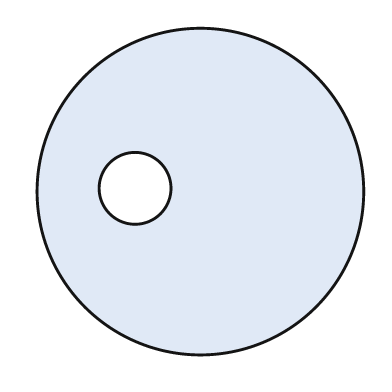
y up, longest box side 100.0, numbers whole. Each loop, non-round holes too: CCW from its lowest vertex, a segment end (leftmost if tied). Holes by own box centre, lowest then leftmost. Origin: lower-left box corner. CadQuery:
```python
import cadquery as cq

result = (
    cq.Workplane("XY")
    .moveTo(50.0, 50.0)
    .circle(50.0)
    .moveTo(30.0, 51.0)
    .circle(11.0)
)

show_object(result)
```